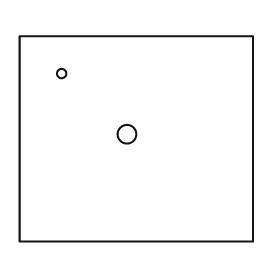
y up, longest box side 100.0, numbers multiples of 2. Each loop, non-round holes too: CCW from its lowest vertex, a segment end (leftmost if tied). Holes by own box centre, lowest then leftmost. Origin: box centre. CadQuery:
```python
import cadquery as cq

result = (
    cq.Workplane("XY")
    .moveTo(-50.0, -44.0)
    .lineTo(50.0, -44.0)
    .lineTo(50.0, 44.0)
    .lineTo(-50.0, 44.0)
    .close()
    .moveTo(-4.0, 2.0)
    .circle(4.0)
    .moveTo(-32.0, 28.0)
    .circle(2.0)
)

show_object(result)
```